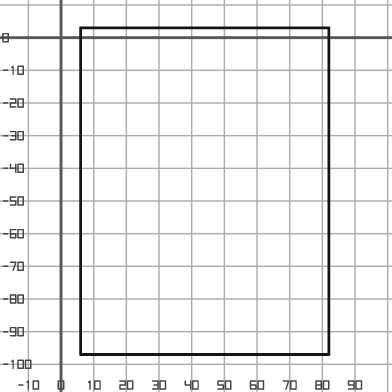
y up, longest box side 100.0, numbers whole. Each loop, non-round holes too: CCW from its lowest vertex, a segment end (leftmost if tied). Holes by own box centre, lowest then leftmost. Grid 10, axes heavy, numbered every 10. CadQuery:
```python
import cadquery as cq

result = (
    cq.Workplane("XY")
    .moveTo(6.0, -97.0)
    .lineTo(82.0, -97.0)
    .lineTo(82.0, 3.0)
    .lineTo(6.0, 3.0)
    .close()
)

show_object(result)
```